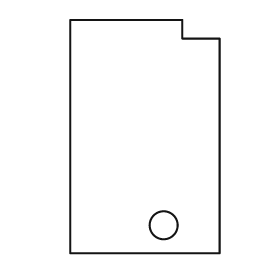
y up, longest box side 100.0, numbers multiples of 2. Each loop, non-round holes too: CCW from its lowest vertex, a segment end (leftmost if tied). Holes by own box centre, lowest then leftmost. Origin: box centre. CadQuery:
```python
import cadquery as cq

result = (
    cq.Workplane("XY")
    .moveTo(-32.0, -50.0)
    .lineTo(32.0, -50.0)
    .lineTo(32.0, 42.0)
    .lineTo(16.0, 42.0)
    .lineTo(16.0, 50.0)
    .lineTo(-32.0, 50.0)
    .close()
    .moveTo(8.0, -38.0)
    .circle(6.0)
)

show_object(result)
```